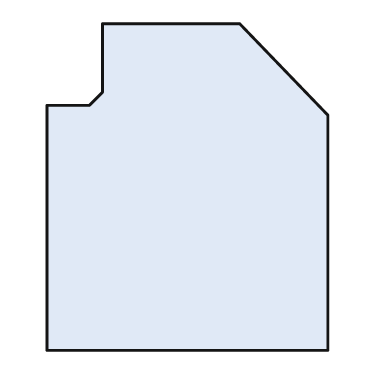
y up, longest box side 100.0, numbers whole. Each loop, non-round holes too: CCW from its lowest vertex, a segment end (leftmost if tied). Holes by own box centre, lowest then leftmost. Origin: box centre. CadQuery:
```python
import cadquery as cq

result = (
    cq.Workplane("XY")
    .moveTo(-43.0, -50.0)
    .lineTo(43.0, -50.0)
    .lineTo(43.0, 22.0)
    .lineTo(16.0, 50.0)
    .lineTo(-26.0, 50.0)
    .lineTo(-26.0, 29.0)
    .lineTo(-30.0, 25.0)
    .lineTo(-43.0, 25.0)
    .close()
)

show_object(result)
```